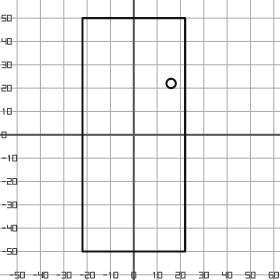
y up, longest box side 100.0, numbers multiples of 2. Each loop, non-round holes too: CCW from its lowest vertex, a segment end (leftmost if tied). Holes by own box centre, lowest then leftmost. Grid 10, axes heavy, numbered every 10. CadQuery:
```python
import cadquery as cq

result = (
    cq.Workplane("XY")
    .moveTo(-22.0, -50.0)
    .lineTo(22.0, -50.0)
    .lineTo(22.0, 50.0)
    .lineTo(-22.0, 50.0)
    .close()
    .moveTo(16.0, 22.0)
    .circle(2.0)
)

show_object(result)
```